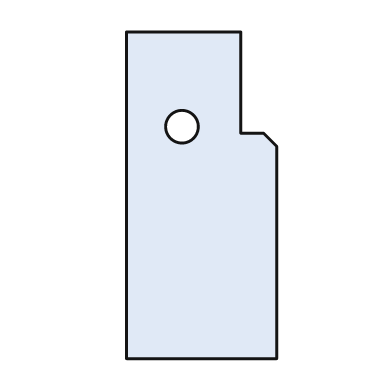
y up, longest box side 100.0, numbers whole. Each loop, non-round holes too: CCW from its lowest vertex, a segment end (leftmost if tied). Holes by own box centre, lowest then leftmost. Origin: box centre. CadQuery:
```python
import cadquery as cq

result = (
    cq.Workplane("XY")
    .moveTo(-23.0, -50.0)
    .lineTo(23.0, -50.0)
    .lineTo(23.0, 15.0)
    .lineTo(19.0, 19.0)
    .lineTo(12.0, 19.0)
    .lineTo(12.0, 50.0)
    .lineTo(-23.0, 50.0)
    .close()
    .moveTo(-6.0, 21.0)
    .circle(5.0)
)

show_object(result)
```